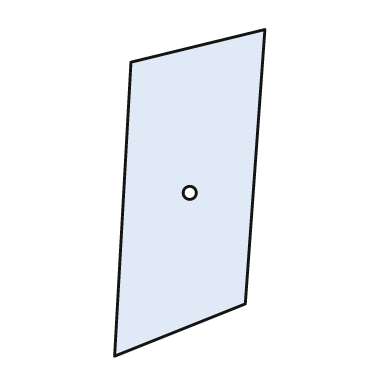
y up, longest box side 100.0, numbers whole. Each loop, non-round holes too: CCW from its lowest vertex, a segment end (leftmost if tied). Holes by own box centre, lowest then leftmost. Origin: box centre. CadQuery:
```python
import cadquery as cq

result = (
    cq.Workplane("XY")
    .moveTo(-23.0, -50.0)
    .lineTo(17.0, -34.0)
    .lineTo(23.0, 50.0)
    .lineTo(-18.0, 40.0)
    .close()
    .moveTo(0.0, 0.0)
    .circle(2.0)
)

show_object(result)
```